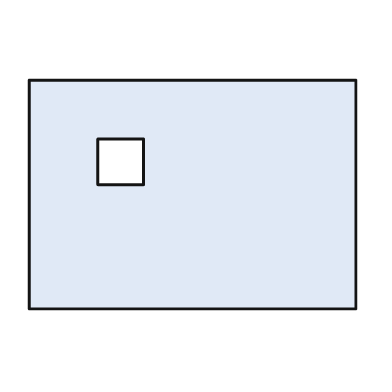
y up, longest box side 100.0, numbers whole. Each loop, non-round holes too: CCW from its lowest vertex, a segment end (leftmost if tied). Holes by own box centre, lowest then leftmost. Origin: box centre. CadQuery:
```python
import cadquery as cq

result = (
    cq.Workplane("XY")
    .moveTo(-50.0, -35.0)
    .lineTo(50.0, -35.0)
    .lineTo(50.0, 35.0)
    .lineTo(-50.0, 35.0)
    .close()
    .moveTo(-29.0, 3.0)
    .lineTo(-15.0, 3.0)
    .lineTo(-15.0, 17.0)
    .lineTo(-29.0, 17.0)
    .close()
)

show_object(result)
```